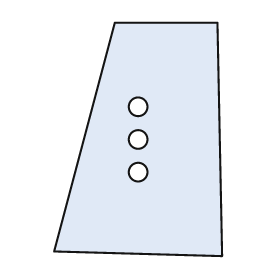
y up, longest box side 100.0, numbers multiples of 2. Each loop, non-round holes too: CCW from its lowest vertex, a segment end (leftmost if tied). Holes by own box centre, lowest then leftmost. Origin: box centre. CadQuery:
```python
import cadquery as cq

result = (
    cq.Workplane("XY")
    .moveTo(36.0, -50.0)
    .lineTo(34.0, 50.0)
    .lineTo(-10.0, 50.0)
    .lineTo(-36.0, -48.0)
    .close()
    .moveTo(0.0, -14.0)
    .circle(4.0)
    .moveTo(0.0, 0.0)
    .circle(4.0)
    .moveTo(0.0, 14.0)
    .circle(4.0)
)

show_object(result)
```